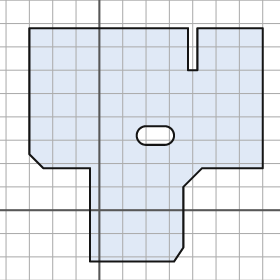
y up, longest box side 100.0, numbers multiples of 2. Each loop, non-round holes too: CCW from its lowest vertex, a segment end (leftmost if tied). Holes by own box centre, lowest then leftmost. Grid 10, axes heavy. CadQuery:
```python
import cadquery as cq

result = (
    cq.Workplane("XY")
    .moveTo(-4.0, -22.0)
    .lineTo(32.0, -22.0)
    .lineTo(36.0, -16.0)
    .lineTo(36.0, 10.0)
    .lineTo(44.0, 18.0)
    .lineTo(70.0, 18.0)
    .lineTo(70.0, 78.0)
    .lineTo(42.0, 78.0)
    .lineTo(42.0, 60.0)
    .lineTo(38.0, 60.0)
    .lineTo(38.0, 78.0)
    .lineTo(-30.0, 78.0)
    .lineTo(-30.0, 24.0)
    .lineTo(-24.0, 18.0)
    .lineTo(-4.0, 18.0)
    .close()
    .moveTo(20.0, 28.0)
    .lineTo(28.0, 28.0)
    .threePointArc((32.0, 32.0), (28.0, 36.0))
    .lineTo(20.0, 36.0)
    .threePointArc((16.0, 32.0), (20.0, 28.0))
    .close()
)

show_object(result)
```